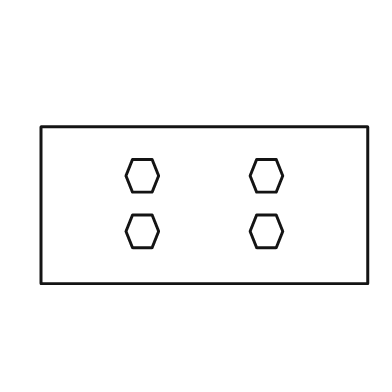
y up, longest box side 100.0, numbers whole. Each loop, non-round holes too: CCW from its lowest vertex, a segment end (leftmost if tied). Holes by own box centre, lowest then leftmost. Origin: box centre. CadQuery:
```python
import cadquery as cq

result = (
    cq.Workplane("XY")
    .moveTo(-50.0, -24.0)
    .lineTo(50.0, -24.0)
    .lineTo(50.0, 24.0)
    .lineTo(-50.0, 24.0)
    .close()
    .moveTo(-22.0, -13.0)
    .lineTo(-16.0, -13.0)
    .lineTo(-14.0, -8.0)
    .lineTo(-16.0, -3.0)
    .lineTo(-22.0, -3.0)
    .lineTo(-24.0, -8.0)
    .close()
    .moveTo(16.0, -13.0)
    .lineTo(22.0, -13.0)
    .lineTo(24.0, -8.0)
    .lineTo(22.0, -3.0)
    .lineTo(16.0, -3.0)
    .lineTo(14.0, -8.0)
    .close()
    .moveTo(-22.0, 4.0)
    .lineTo(-16.0, 4.0)
    .lineTo(-14.0, 9.0)
    .lineTo(-16.0, 14.0)
    .lineTo(-22.0, 14.0)
    .lineTo(-24.0, 9.0)
    .close()
    .moveTo(16.0, 4.0)
    .lineTo(22.0, 4.0)
    .lineTo(24.0, 9.0)
    .lineTo(22.0, 14.0)
    .lineTo(16.0, 14.0)
    .lineTo(14.0, 9.0)
    .close()
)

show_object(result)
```